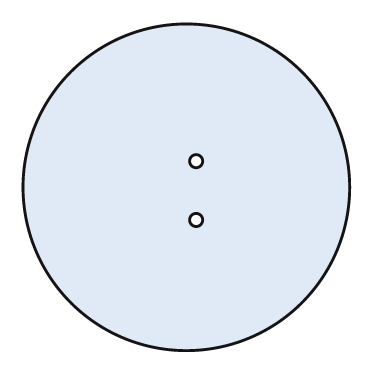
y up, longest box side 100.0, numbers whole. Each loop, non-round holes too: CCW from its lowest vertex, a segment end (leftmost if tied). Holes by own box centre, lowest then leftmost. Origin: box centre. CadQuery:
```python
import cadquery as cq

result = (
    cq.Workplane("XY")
    .moveTo(0.0, 0.0)
    .circle(50.0)
    .moveTo(3.0, -10.0)
    .circle(2.0)
    .moveTo(3.0, 8.0)
    .circle(2.0)
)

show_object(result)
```